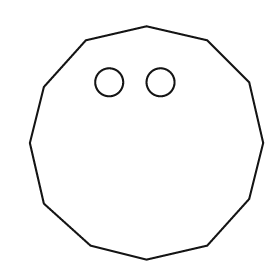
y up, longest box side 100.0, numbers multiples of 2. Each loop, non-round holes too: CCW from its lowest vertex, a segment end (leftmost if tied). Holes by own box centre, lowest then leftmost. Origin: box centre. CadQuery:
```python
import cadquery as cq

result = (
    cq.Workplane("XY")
    .moveTo(0.0, -50.0)
    .lineTo(26.0, -44.0)
    .lineTo(44.0, -24.0)
    .lineTo(50.0, 0.0)
    .lineTo(44.0, 26.0)
    .lineTo(26.0, 44.0)
    .lineTo(0.0, 50.0)
    .lineTo(-26.0, 44.0)
    .lineTo(-44.0, 24.0)
    .lineTo(-50.0, 0.0)
    .lineTo(-44.0, -26.0)
    .lineTo(-24.0, -44.0)
    .close()
    .moveTo(-16.0, 26.0)
    .circle(6.0)
    .moveTo(6.0, 26.0)
    .circle(6.0)
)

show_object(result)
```